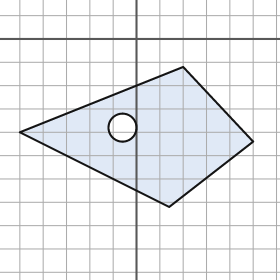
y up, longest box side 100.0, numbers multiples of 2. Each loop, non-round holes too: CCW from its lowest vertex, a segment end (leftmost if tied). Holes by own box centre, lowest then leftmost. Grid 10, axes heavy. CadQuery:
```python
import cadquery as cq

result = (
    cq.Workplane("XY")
    .moveTo(14.0, -72.0)
    .lineTo(50.0, -44.0)
    .lineTo(20.0, -12.0)
    .lineTo(-50.0, -40.0)
    .close()
    .moveTo(-6.0, -38.0)
    .circle(6.0)
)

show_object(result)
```